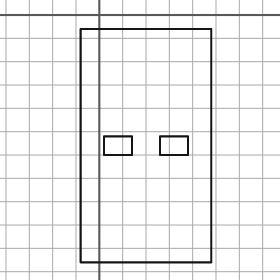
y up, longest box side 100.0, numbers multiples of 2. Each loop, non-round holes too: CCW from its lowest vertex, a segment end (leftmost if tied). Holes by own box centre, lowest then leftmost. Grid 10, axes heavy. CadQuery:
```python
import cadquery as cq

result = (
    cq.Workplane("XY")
    .moveTo(-8.0, -106.0)
    .lineTo(48.0, -106.0)
    .lineTo(48.0, -6.0)
    .lineTo(-8.0, -6.0)
    .close()
    .moveTo(2.0, -60.0)
    .lineTo(14.0, -60.0)
    .lineTo(14.0, -52.0)
    .lineTo(2.0, -52.0)
    .close()
    .moveTo(26.0, -60.0)
    .lineTo(38.0, -60.0)
    .lineTo(38.0, -52.0)
    .lineTo(26.0, -52.0)
    .close()
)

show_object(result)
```